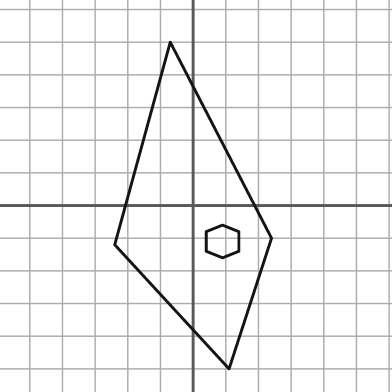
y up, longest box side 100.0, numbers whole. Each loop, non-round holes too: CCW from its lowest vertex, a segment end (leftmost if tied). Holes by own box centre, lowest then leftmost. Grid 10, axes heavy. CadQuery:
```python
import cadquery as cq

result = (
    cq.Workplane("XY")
    .moveTo(11.0, -50.0)
    .lineTo(24.0, -10.0)
    .lineTo(-7.0, 50.0)
    .lineTo(-24.0, -12.0)
    .close()
    .moveTo(9.0, -16.0)
    .lineTo(14.0, -14.0)
    .lineTo(14.0, -8.0)
    .lineTo(9.0, -6.0)
    .lineTo(4.0, -8.0)
    .lineTo(4.0, -14.0)
    .close()
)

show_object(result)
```